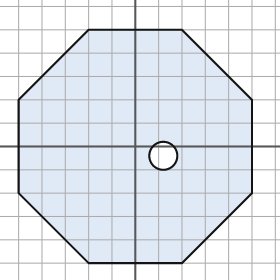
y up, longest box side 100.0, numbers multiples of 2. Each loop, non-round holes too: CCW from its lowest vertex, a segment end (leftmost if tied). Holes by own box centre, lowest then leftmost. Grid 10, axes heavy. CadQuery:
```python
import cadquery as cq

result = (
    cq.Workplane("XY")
    .moveTo(-20.0, -50.0)
    .lineTo(20.0, -50.0)
    .lineTo(50.0, -20.0)
    .lineTo(50.0, 20.0)
    .lineTo(20.0, 50.0)
    .lineTo(-20.0, 50.0)
    .lineTo(-50.0, 20.0)
    .lineTo(-50.0, -20.0)
    .close()
    .moveTo(12.0, -4.0)
    .circle(6.0)
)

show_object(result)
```